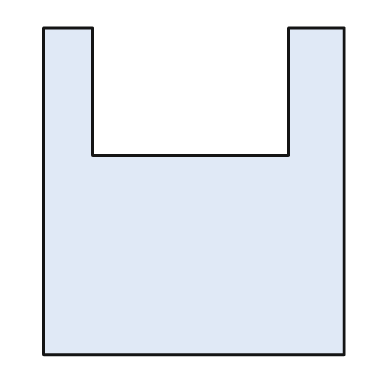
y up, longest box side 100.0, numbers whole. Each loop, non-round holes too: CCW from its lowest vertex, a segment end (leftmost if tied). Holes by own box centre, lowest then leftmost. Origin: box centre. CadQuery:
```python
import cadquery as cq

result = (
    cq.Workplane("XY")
    .moveTo(-46.0, -50.0)
    .lineTo(46.0, -50.0)
    .lineTo(46.0, 50.0)
    .lineTo(29.0, 50.0)
    .lineTo(29.0, 11.0)
    .lineTo(-31.0, 11.0)
    .lineTo(-31.0, 50.0)
    .lineTo(-46.0, 50.0)
    .close()
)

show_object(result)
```